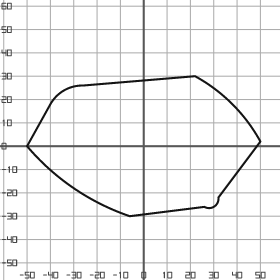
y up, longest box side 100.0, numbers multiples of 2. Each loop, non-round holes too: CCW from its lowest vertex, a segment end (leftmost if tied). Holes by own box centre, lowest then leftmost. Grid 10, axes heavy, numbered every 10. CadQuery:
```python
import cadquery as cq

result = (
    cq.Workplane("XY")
    .moveTo(-6.0, -30.0)
    .lineTo(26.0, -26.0)
    .threePointArc((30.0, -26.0), (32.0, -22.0))
    .lineTo(50.0, 2.0)
    .threePointArc((38.0, 18.0), (22.0, 30.0))
    .lineTo(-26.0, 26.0)
    .threePointArc((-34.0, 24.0), (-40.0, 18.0))
    .lineTo(-50.0, 0.0)
    .threePointArc((-30.0, -18.0), (-6.0, -30.0))
    .close()
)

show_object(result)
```